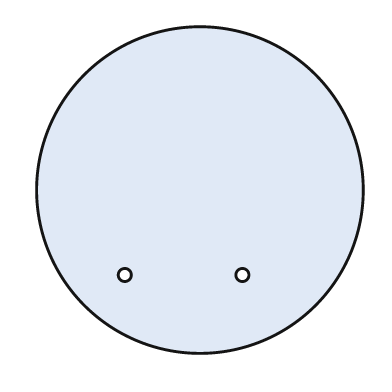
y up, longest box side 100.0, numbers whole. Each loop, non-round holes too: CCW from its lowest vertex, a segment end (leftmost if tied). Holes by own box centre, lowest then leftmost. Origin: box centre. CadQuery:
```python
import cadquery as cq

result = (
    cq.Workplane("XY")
    .moveTo(0.0, 0.0)
    .circle(50.0)
    .moveTo(-23.0, -26.0)
    .circle(2.0)
    .moveTo(13.0, -26.0)
    .circle(2.0)
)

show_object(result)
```